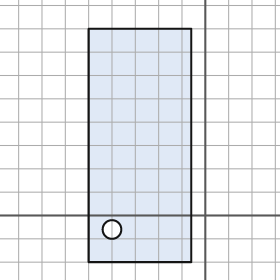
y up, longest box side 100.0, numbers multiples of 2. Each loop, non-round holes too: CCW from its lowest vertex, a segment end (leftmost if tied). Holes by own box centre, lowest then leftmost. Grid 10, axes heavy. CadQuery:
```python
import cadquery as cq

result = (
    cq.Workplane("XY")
    .moveTo(-50.0, -20.0)
    .lineTo(-6.0, -20.0)
    .lineTo(-6.0, 80.0)
    .lineTo(-50.0, 80.0)
    .close()
    .moveTo(-40.0, -6.0)
    .circle(4.0)
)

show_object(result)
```